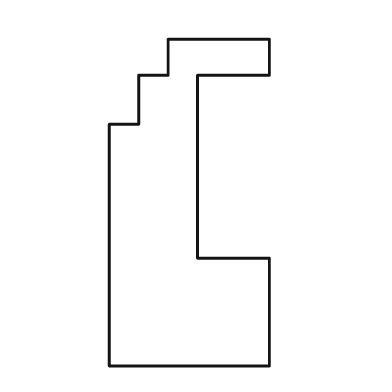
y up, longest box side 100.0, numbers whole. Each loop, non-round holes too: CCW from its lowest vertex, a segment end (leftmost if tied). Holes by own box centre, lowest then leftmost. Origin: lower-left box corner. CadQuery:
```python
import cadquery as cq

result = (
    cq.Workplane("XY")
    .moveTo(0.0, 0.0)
    .lineTo(49.0, 0.0)
    .lineTo(49.0, 33.0)
    .lineTo(27.0, 33.0)
    .lineTo(27.0, 89.0)
    .lineTo(49.0, 89.0)
    .lineTo(49.0, 100.0)
    .lineTo(18.0, 100.0)
    .lineTo(18.0, 89.0)
    .lineTo(9.0, 89.0)
    .lineTo(9.0, 74.0)
    .lineTo(0.0, 74.0)
    .close()
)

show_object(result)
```